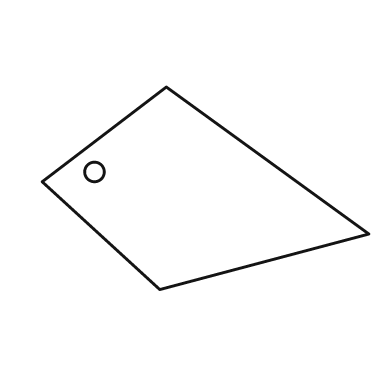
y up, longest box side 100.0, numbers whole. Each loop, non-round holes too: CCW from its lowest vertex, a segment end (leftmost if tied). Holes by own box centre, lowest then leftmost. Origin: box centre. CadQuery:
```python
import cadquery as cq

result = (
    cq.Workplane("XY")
    .moveTo(-14.0, -31.0)
    .lineTo(50.0, -14.0)
    .lineTo(-12.0, 31.0)
    .lineTo(-50.0, 2.0)
    .close()
    .moveTo(-34.0, 5.0)
    .circle(3.0)
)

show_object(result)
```